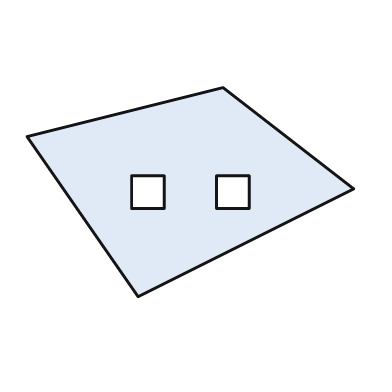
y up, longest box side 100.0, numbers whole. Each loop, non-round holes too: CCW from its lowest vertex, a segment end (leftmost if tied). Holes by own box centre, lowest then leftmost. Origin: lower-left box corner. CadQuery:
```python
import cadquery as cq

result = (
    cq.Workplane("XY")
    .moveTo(34.0, 0.0)
    .lineTo(100.0, 33.0)
    .lineTo(60.0, 64.0)
    .lineTo(0.0, 49.0)
    .close()
    .moveTo(32.0, 27.0)
    .lineTo(42.0, 27.0)
    .lineTo(42.0, 37.0)
    .lineTo(32.0, 37.0)
    .close()
    .moveTo(58.0, 27.0)
    .lineTo(68.0, 27.0)
    .lineTo(68.0, 37.0)
    .lineTo(58.0, 37.0)
    .close()
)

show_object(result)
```